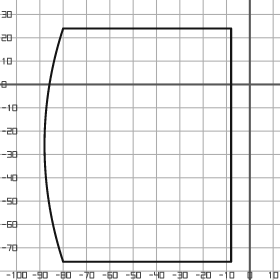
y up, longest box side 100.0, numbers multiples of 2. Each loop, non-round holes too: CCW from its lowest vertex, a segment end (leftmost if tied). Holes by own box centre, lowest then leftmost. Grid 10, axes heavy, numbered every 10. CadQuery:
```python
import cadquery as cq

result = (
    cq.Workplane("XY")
    .moveTo(-80.0, -76.0)
    .lineTo(-8.0, -76.0)
    .lineTo(-8.0, 24.0)
    .lineTo(-80.0, 24.0)
    .threePointArc((-88.0, -26.0), (-80.0, -76.0))
    .close()
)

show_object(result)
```